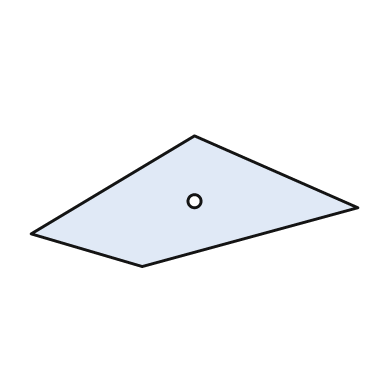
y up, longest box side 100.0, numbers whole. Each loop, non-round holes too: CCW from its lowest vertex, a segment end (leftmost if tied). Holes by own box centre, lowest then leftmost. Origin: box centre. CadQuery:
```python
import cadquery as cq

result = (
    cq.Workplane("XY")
    .moveTo(-16.0, -20.0)
    .lineTo(50.0, -2.0)
    .lineTo(0.0, 20.0)
    .lineTo(-50.0, -10.0)
    .close()
    .moveTo(0.0, 0.0)
    .circle(2.0)
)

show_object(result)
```